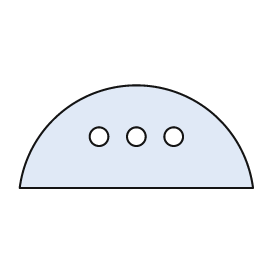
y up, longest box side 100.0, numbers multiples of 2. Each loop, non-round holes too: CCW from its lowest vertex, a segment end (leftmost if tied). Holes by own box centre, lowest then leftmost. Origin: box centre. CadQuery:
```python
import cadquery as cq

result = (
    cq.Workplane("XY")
    .moveTo(-50.0, -22.0)
    .lineTo(50.0, -22.0)
    .threePointArc((0.0, 22.0), (-50.0, -22.0))
    .close()
    .moveTo(-16.0, 0.0)
    .circle(4.0)
    .moveTo(0.0, 0.0)
    .circle(4.0)
    .moveTo(16.0, 0.0)
    .circle(4.0)
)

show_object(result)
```